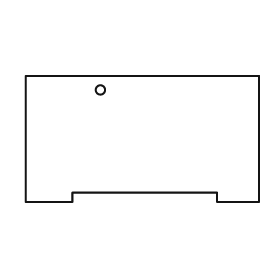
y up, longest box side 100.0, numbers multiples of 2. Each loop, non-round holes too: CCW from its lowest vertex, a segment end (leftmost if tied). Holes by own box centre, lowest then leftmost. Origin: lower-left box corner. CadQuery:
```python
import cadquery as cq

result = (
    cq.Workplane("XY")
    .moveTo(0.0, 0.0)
    .lineTo(20.0, 0.0)
    .lineTo(20.0, 4.0)
    .lineTo(82.0, 4.0)
    .lineTo(82.0, 0.0)
    .lineTo(100.0, 0.0)
    .lineTo(100.0, 54.0)
    .lineTo(0.0, 54.0)
    .close()
    .moveTo(32.0, 48.0)
    .circle(2.0)
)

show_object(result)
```